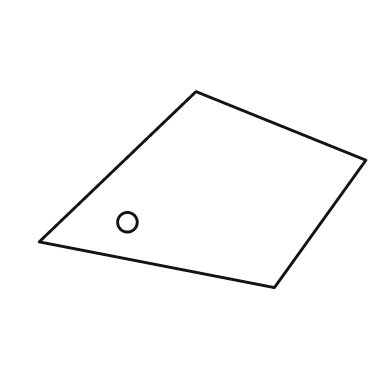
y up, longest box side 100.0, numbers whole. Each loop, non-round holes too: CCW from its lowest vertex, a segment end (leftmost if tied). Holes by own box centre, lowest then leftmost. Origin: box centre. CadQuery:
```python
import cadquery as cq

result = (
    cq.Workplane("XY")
    .moveTo(22.0, -30.0)
    .lineTo(50.0, 9.0)
    .lineTo(-2.0, 30.0)
    .lineTo(-50.0, -16.0)
    .close()
    .moveTo(-23.0, -10.0)
    .circle(3.0)
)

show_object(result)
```